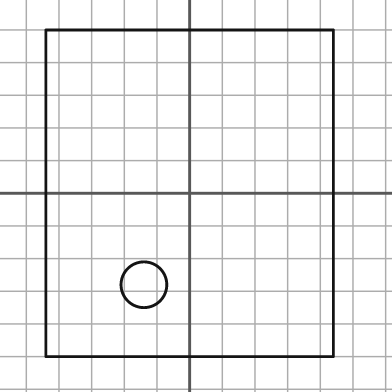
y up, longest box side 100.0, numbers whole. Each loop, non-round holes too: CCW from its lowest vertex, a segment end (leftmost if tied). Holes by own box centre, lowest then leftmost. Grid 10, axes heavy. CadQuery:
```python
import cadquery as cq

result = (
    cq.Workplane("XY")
    .moveTo(-44.0, -50.0)
    .lineTo(44.0, -50.0)
    .lineTo(44.0, 50.0)
    .lineTo(-44.0, 50.0)
    .close()
    .moveTo(-14.0, -28.0)
    .circle(7.0)
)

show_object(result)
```